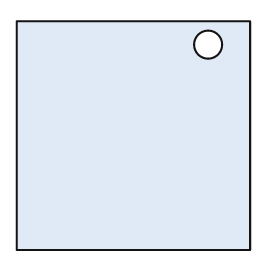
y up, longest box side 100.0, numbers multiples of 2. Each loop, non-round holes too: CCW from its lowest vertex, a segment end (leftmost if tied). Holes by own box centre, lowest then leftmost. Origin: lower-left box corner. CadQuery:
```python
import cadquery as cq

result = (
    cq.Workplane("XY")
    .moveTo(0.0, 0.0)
    .lineTo(100.0, 0.0)
    .lineTo(100.0, 98.0)
    .lineTo(0.0, 98.0)
    .close()
    .moveTo(82.0, 88.0)
    .circle(6.0)
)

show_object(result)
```